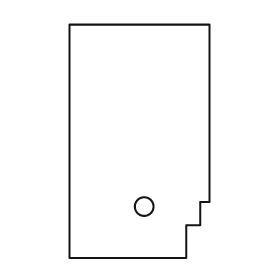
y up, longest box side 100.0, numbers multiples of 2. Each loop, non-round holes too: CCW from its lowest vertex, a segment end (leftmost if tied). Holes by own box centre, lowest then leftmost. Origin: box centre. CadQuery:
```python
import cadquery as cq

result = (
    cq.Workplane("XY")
    .moveTo(-30.0, -50.0)
    .lineTo(20.0, -50.0)
    .lineTo(20.0, -36.0)
    .lineTo(26.0, -36.0)
    .lineTo(26.0, -26.0)
    .lineTo(30.0, -26.0)
    .lineTo(30.0, 50.0)
    .lineTo(-30.0, 50.0)
    .close()
    .moveTo(2.0, -28.0)
    .circle(4.0)
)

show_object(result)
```